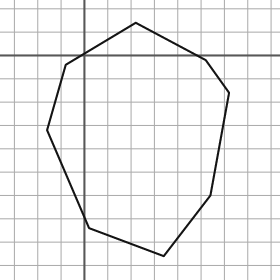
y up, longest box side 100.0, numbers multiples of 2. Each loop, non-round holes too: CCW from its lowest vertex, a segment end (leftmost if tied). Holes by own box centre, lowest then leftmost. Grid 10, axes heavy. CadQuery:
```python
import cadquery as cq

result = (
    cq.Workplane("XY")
    .moveTo(34.0, -86.0)
    .lineTo(54.0, -60.0)
    .lineTo(62.0, -16.0)
    .lineTo(52.0, -2.0)
    .lineTo(22.0, 14.0)
    .lineTo(-8.0, -4.0)
    .lineTo(-16.0, -32.0)
    .lineTo(2.0, -74.0)
    .close()
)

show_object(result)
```